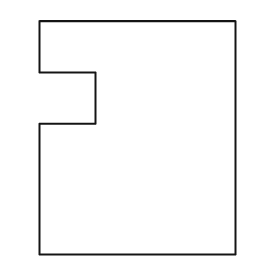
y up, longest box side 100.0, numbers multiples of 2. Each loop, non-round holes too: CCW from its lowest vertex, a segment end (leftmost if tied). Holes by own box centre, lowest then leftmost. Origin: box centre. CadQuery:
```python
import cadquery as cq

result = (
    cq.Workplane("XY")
    .moveTo(-42.0, -50.0)
    .lineTo(42.0, -50.0)
    .lineTo(42.0, 50.0)
    .lineTo(-42.0, 50.0)
    .lineTo(-42.0, 28.0)
    .lineTo(-18.0, 28.0)
    .lineTo(-18.0, 6.0)
    .lineTo(-42.0, 6.0)
    .close()
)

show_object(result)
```